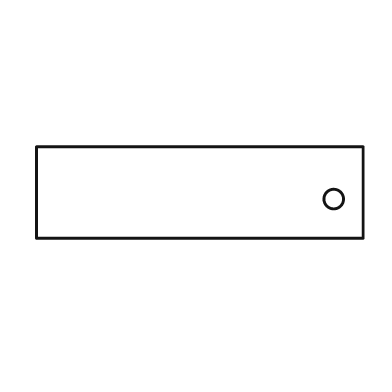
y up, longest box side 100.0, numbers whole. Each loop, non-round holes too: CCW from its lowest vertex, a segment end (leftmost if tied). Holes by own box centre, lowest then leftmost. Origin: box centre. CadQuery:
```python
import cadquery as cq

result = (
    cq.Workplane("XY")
    .moveTo(-50.0, -14.0)
    .lineTo(50.0, -14.0)
    .lineTo(50.0, 14.0)
    .lineTo(-50.0, 14.0)
    .close()
    .moveTo(41.0, -2.0)
    .circle(3.0)
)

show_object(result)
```